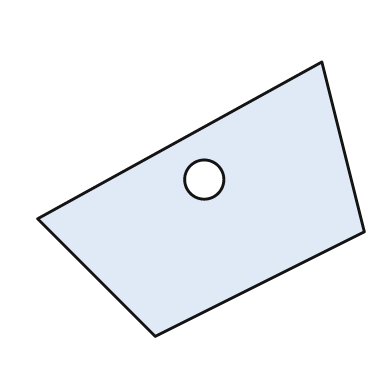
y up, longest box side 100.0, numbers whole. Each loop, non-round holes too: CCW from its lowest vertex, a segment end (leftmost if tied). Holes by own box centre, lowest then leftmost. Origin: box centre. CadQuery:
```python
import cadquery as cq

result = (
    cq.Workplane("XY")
    .moveTo(-14.0, -42.0)
    .lineTo(50.0, -10.0)
    .lineTo(37.0, 42.0)
    .lineTo(-50.0, -6.0)
    .close()
    .moveTo(1.0, 6.0)
    .circle(6.0)
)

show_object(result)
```